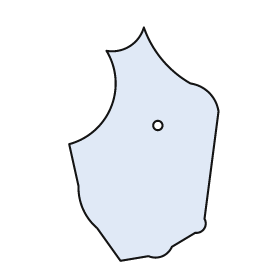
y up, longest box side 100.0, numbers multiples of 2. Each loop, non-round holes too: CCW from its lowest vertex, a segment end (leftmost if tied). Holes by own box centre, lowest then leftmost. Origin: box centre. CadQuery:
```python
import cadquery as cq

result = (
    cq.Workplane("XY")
    .moveTo(-10.0, -50.0)
    .lineTo(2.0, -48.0)
    .threePointArc((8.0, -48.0), (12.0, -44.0))
    .lineTo(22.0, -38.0)
    .threePointArc((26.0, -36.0), (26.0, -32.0))
    .lineTo(32.0, 14.0)
    .threePointArc((28.0, 22.0), (20.0, 26.0))
    .threePointArc((8.0, 36.0), (0.0, 50.0))
    .threePointArc((-6.0, 42.0), (-16.0, 40.0))
    .threePointArc((-14.0, 16.0), (-32.0, 0.0))
    .lineTo(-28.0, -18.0)
    .threePointArc((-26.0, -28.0), (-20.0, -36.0))
    .close()
    .moveTo(6.0, 8.0)
    .circle(2.0)
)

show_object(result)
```